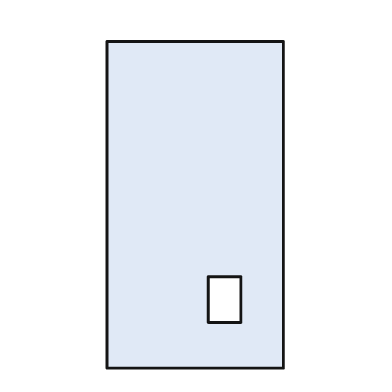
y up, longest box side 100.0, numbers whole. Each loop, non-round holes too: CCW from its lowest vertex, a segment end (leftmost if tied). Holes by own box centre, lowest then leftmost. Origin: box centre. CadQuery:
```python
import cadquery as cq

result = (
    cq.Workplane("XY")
    .moveTo(-27.0, -50.0)
    .lineTo(27.0, -50.0)
    .lineTo(27.0, 50.0)
    .lineTo(-27.0, 50.0)
    .close()
    .moveTo(4.0, -36.0)
    .lineTo(14.0, -36.0)
    .lineTo(14.0, -22.0)
    .lineTo(4.0, -22.0)
    .close()
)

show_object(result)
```